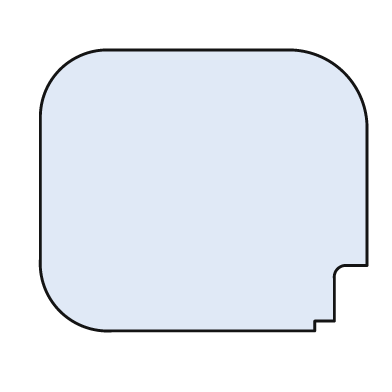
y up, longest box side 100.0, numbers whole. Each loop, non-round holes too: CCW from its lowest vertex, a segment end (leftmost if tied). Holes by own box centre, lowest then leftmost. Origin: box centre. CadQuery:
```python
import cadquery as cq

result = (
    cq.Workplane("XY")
    .moveTo(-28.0, -43.0)
    .lineTo(34.0, -43.0)
    .lineTo(34.0, -40.0)
    .lineTo(40.0, -40.0)
    .lineTo(40.0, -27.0)
    .threePointArc((41.0, -24.0), (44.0, -23.0))
    .lineTo(50.0, -23.0)
    .lineTo(50.0, 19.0)
    .threePointArc((43.0, 36.0), (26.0, 43.0))
    .lineTo(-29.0, 43.0)
    .threePointArc((-44.0, 37.0), (-50.0, 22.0))
    .lineTo(-50.0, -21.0)
    .threePointArc((-44.0, -37.0), (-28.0, -43.0))
    .close()
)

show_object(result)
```